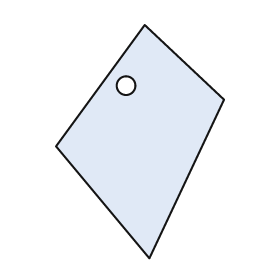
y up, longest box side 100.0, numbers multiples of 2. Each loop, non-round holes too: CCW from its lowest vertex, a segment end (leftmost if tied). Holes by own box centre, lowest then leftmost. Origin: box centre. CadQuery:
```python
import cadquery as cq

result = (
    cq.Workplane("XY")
    .moveTo(4.0, -50.0)
    .lineTo(36.0, 18.0)
    .lineTo(2.0, 50.0)
    .lineTo(-36.0, -2.0)
    .close()
    .moveTo(-6.0, 24.0)
    .circle(4.0)
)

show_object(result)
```